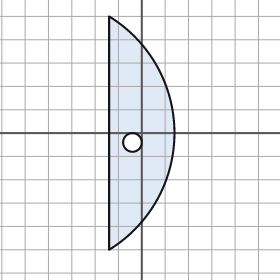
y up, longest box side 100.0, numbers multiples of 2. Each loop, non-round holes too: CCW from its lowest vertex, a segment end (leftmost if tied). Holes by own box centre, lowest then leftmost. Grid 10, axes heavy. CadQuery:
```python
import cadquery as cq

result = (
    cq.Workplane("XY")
    .moveTo(-14.0, -50.0)
    .threePointArc((14.0, 0.0), (-14.0, 50.0))
    .close()
    .moveTo(-4.0, -4.0)
    .circle(4.0)
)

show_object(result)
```